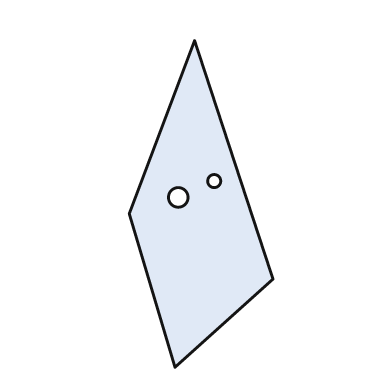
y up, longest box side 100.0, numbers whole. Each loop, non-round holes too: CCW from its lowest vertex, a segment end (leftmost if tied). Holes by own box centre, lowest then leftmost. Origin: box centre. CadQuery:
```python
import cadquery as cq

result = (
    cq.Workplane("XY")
    .moveTo(-8.0, -50.0)
    .lineTo(22.0, -23.0)
    .lineTo(-2.0, 50.0)
    .lineTo(-22.0, -3.0)
    .close()
    .moveTo(-7.0, 2.0)
    .circle(3.0)
    .moveTo(4.0, 7.0)
    .circle(2.0)
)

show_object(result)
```